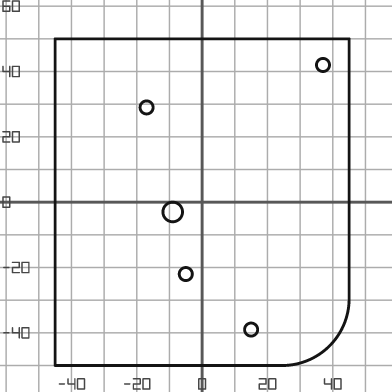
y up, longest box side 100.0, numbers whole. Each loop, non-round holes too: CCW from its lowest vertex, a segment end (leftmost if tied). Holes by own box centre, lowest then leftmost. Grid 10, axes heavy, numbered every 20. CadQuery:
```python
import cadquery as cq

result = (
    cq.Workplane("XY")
    .moveTo(-45.0, -50.0)
    .lineTo(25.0, -50.0)
    .threePointArc((39.0, -44.0), (45.0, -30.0))
    .lineTo(45.0, 50.0)
    .lineTo(-45.0, 50.0)
    .close()
    .moveTo(15.0, -39.0)
    .circle(2.0)
    .moveTo(-5.0, -22.0)
    .circle(2.0)
    .moveTo(-9.0, -3.0)
    .circle(3.0)
    .moveTo(-17.0, 29.0)
    .circle(2.0)
    .moveTo(37.0, 42.0)
    .circle(2.0)
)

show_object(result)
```